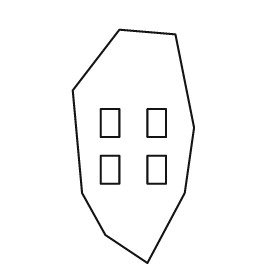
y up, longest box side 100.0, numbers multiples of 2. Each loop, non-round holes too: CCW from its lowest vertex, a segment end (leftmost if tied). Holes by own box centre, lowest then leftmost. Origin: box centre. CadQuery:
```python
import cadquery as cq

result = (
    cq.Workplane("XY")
    .moveTo(6.0, -50.0)
    .lineTo(22.0, -20.0)
    .lineTo(26.0, 8.0)
    .lineTo(18.0, 48.0)
    .lineTo(-6.0, 50.0)
    .lineTo(-26.0, 24.0)
    .lineTo(-22.0, -20.0)
    .lineTo(-12.0, -38.0)
    .close()
    .moveTo(-14.0, -16.0)
    .lineTo(-6.0, -16.0)
    .lineTo(-6.0, -4.0)
    .lineTo(-14.0, -4.0)
    .close()
    .moveTo(6.0, -16.0)
    .lineTo(14.0, -16.0)
    .lineTo(14.0, -4.0)
    .lineTo(6.0, -4.0)
    .close()
    .moveTo(-14.0, 4.0)
    .lineTo(-6.0, 4.0)
    .lineTo(-6.0, 16.0)
    .lineTo(-14.0, 16.0)
    .close()
    .moveTo(6.0, 4.0)
    .lineTo(14.0, 4.0)
    .lineTo(14.0, 16.0)
    .lineTo(6.0, 16.0)
    .close()
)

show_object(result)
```